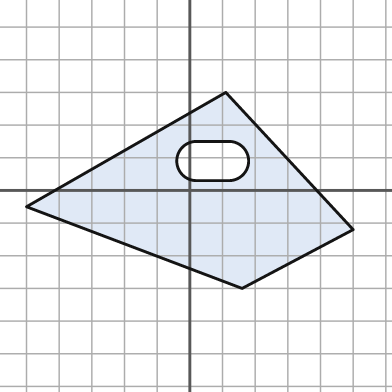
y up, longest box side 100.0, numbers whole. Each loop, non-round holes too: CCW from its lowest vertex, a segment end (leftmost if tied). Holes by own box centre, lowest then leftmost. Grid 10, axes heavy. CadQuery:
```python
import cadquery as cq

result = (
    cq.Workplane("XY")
    .moveTo(16.0, -30.0)
    .lineTo(50.0, -12.0)
    .lineTo(11.0, 30.0)
    .lineTo(-50.0, -5.0)
    .close()
    .moveTo(2.0, 3.0)
    .lineTo(12.0, 3.0)
    .threePointArc((18.0, 9.0), (12.0, 15.0))
    .lineTo(2.0, 15.0)
    .threePointArc((-4.0, 9.0), (2.0, 3.0))
    .close()
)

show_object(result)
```